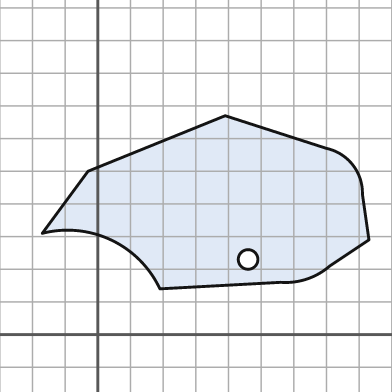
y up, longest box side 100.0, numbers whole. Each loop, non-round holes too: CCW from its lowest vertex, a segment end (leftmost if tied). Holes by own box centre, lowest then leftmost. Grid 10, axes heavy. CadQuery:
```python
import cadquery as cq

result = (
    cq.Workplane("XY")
    .moveTo(19.0, 14.0)
    .lineTo(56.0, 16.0)
    .threePointArc((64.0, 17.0), (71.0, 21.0))
    .lineTo(83.0, 29.0)
    .lineTo(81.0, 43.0)
    .threePointArc((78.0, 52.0), (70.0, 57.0))
    .lineTo(39.0, 67.0)
    .lineTo(-3.0, 50.0)
    .lineTo(-17.0, 31.0)
    .threePointArc((4.0, 29.0), (19.0, 14.0))
    .close()
    .moveTo(46.0, 23.0)
    .circle(3.0)
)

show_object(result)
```